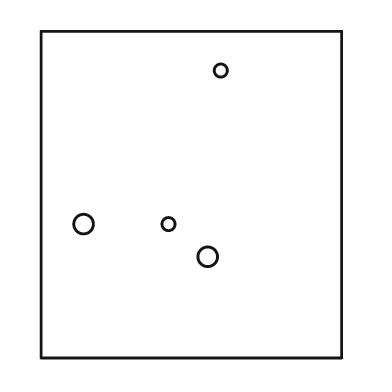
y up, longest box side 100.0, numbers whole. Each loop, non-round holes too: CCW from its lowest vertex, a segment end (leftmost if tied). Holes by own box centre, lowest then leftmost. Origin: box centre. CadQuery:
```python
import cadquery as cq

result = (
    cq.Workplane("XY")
    .moveTo(-46.0, -50.0)
    .lineTo(46.0, -50.0)
    .lineTo(46.0, 50.0)
    .lineTo(-46.0, 50.0)
    .close()
    .moveTo(5.0, -19.0)
    .circle(3.0)
    .moveTo(-33.0, -9.0)
    .circle(3.0)
    .moveTo(-7.0, -9.0)
    .circle(2.0)
    .moveTo(9.0, 38.0)
    .circle(2.0)
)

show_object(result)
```